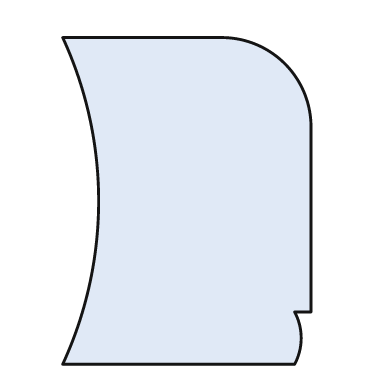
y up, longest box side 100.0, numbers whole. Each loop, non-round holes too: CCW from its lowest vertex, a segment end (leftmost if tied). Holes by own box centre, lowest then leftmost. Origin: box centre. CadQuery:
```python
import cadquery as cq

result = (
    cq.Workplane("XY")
    .moveTo(-38.0, -50.0)
    .lineTo(33.0, -50.0)
    .threePointArc((35.0, -42.0), (33.0, -34.0))
    .lineTo(38.0, -34.0)
    .lineTo(38.0, 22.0)
    .threePointArc((30.0, 42.0), (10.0, 50.0))
    .lineTo(-38.0, 50.0)
    .threePointArc((-27.0, 0.0), (-38.0, -50.0))
    .close()
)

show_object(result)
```